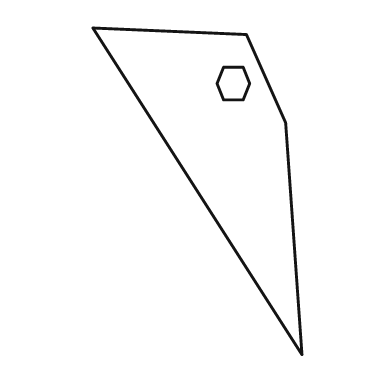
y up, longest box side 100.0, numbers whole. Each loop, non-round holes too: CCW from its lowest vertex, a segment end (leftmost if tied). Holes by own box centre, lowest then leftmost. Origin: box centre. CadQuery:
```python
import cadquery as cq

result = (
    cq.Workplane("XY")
    .moveTo(32.0, -50.0)
    .lineTo(27.0, 21.0)
    .lineTo(15.0, 48.0)
    .lineTo(-32.0, 50.0)
    .close()
    .moveTo(8.0, 28.0)
    .lineTo(14.0, 28.0)
    .lineTo(16.0, 33.0)
    .lineTo(14.0, 38.0)
    .lineTo(8.0, 38.0)
    .lineTo(6.0, 33.0)
    .close()
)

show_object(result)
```